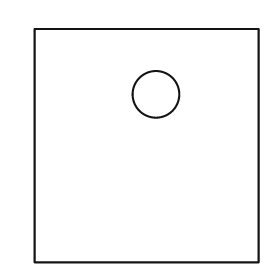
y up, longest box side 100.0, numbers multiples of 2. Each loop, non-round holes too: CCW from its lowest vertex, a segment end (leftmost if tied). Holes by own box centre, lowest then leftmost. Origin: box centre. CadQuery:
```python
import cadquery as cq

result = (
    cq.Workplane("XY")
    .moveTo(-48.0, -50.0)
    .lineTo(48.0, -50.0)
    .lineTo(48.0, 50.0)
    .lineTo(-48.0, 50.0)
    .close()
    .moveTo(4.0, 22.0)
    .circle(10.0)
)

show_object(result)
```